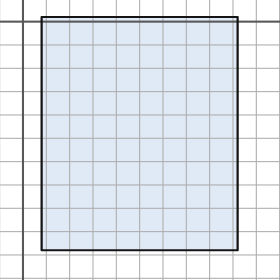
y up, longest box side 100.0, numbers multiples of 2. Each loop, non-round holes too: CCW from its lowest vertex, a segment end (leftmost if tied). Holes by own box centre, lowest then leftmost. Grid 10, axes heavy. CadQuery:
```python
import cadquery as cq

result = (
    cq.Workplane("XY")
    .moveTo(8.0, -98.0)
    .lineTo(92.0, -98.0)
    .lineTo(92.0, 2.0)
    .lineTo(8.0, 2.0)
    .close()
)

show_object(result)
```